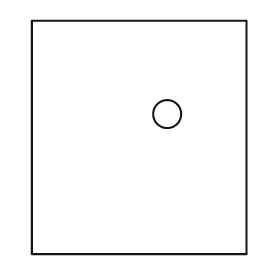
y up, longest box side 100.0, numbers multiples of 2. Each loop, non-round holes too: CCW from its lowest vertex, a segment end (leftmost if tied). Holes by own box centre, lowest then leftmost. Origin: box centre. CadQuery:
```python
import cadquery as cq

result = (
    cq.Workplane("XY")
    .moveTo(-46.0, -50.0)
    .lineTo(46.0, -50.0)
    .lineTo(46.0, 50.0)
    .lineTo(-46.0, 50.0)
    .close()
    .moveTo(12.0, 10.0)
    .circle(6.0)
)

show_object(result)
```